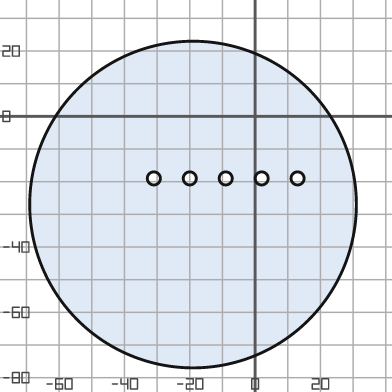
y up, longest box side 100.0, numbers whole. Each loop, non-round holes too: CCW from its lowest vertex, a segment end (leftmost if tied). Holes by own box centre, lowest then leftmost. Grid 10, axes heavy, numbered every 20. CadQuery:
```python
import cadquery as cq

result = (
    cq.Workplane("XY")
    .moveTo(-19.0, -27.0)
    .circle(50.0)
    .moveTo(-31.0, -19.0)
    .circle(2.0)
    .moveTo(-20.0, -19.0)
    .circle(2.0)
    .moveTo(-9.0, -19.0)
    .circle(2.0)
    .moveTo(2.0, -19.0)
    .circle(2.0)
    .moveTo(13.0, -19.0)
    .circle(2.0)
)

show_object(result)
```